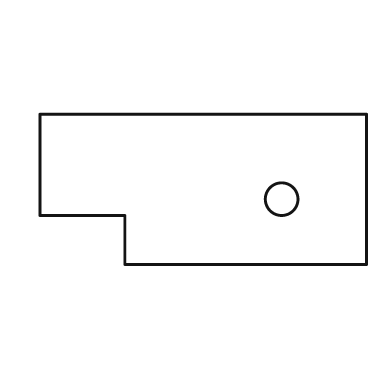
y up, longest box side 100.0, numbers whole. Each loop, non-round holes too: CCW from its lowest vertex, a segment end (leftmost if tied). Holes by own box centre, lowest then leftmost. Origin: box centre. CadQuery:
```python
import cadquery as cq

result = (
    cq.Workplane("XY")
    .moveTo(-24.0, -23.0)
    .lineTo(50.0, -23.0)
    .lineTo(50.0, 23.0)
    .lineTo(-50.0, 23.0)
    .lineTo(-50.0, -8.0)
    .lineTo(-24.0, -8.0)
    .close()
    .moveTo(24.0, -3.0)
    .circle(5.0)
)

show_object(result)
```